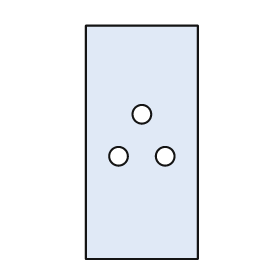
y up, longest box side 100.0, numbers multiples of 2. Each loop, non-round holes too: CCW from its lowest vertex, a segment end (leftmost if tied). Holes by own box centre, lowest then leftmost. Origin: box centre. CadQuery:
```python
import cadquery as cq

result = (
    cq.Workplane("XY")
    .moveTo(-24.0, -50.0)
    .lineTo(24.0, -50.0)
    .lineTo(24.0, 50.0)
    .lineTo(-24.0, 50.0)
    .close()
    .moveTo(-10.0, -6.0)
    .circle(4.0)
    .moveTo(10.0, -6.0)
    .circle(4.0)
    .moveTo(0.0, 12.0)
    .circle(4.0)
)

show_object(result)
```